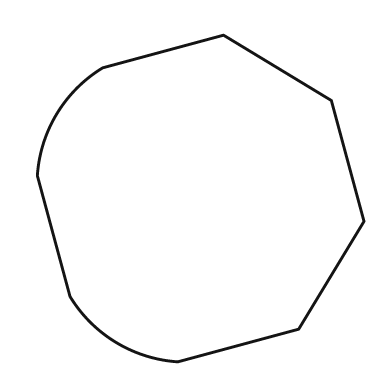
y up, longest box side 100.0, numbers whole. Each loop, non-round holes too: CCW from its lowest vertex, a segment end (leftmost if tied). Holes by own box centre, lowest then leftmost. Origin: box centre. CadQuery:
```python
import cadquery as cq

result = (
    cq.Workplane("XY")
    .moveTo(-7.0, -50.0)
    .lineTo(30.0, -40.0)
    .lineTo(50.0, -7.0)
    .lineTo(40.0, 30.0)
    .lineTo(7.0, 50.0)
    .lineTo(-30.0, 40.0)
    .threePointArc((-44.0, 26.0), (-50.0, 7.0))
    .lineTo(-40.0, -30.0)
    .threePointArc((-26.0, -44.0), (-7.0, -50.0))
    .close()
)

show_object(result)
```